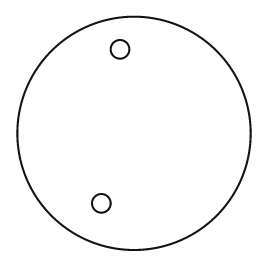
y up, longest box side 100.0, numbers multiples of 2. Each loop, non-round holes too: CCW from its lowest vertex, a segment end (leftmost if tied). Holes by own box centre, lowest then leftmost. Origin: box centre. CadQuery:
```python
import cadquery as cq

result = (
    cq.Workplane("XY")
    .moveTo(0.0, 0.0)
    .circle(50.0)
    .moveTo(-14.0, -30.0)
    .circle(4.0)
    .moveTo(-6.0, 36.0)
    .circle(4.0)
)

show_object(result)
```